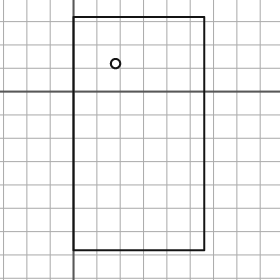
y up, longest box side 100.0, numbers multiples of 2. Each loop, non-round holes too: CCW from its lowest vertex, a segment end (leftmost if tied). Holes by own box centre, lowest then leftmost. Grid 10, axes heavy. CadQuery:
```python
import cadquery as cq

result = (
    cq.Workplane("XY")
    .moveTo(0.0, -68.0)
    .lineTo(56.0, -68.0)
    .lineTo(56.0, 32.0)
    .lineTo(0.0, 32.0)
    .close()
    .moveTo(18.0, 12.0)
    .circle(2.0)
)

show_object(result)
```